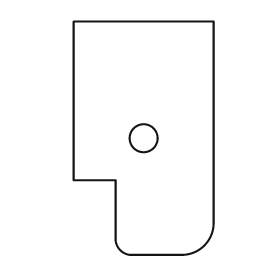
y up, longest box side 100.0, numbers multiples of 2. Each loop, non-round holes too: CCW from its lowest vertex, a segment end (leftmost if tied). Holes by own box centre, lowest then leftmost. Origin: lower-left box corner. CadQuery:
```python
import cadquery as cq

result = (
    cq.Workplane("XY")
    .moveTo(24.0, 0.0)
    .lineTo(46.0, 0.0)
    .threePointArc((56.0, 4.0), (60.0, 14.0))
    .lineTo(60.0, 100.0)
    .lineTo(0.0, 100.0)
    .lineTo(0.0, 32.0)
    .lineTo(18.0, 32.0)
    .lineTo(18.0, 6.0)
    .threePointArc((20.0, 2.0), (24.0, 0.0))
    .close()
    .moveTo(30.0, 50.0)
    .circle(6.0)
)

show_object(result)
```